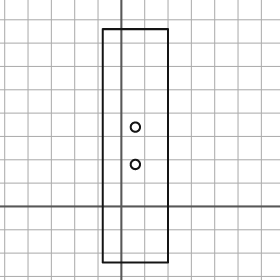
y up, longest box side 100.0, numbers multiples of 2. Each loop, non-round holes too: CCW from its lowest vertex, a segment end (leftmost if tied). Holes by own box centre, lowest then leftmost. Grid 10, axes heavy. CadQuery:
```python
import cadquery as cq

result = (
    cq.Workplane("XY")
    .moveTo(-8.0, -24.0)
    .lineTo(20.0, -24.0)
    .lineTo(20.0, 76.0)
    .lineTo(-8.0, 76.0)
    .close()
    .moveTo(6.0, 18.0)
    .circle(2.0)
    .moveTo(6.0, 34.0)
    .circle(2.0)
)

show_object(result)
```